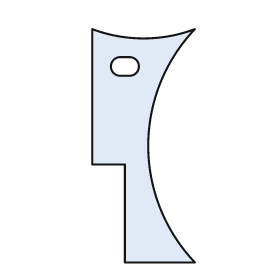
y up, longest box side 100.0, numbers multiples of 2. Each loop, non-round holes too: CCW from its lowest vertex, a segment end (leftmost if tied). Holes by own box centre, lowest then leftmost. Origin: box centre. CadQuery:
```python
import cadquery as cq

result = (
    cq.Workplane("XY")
    .moveTo(-8.0, -50.0)
    .lineTo(22.0, -50.0)
    .threePointArc((2.0, 0.0), (22.0, 50.0))
    .threePointArc((0.0, 46.0), (-22.0, 50.0))
    .lineTo(-22.0, -8.0)
    .lineTo(-8.0, -8.0)
    .close()
    .moveTo(-10.0, 30.0)
    .lineTo(-6.0, 30.0)
    .threePointArc((-2.0, 34.0), (-6.0, 38.0))
    .lineTo(-10.0, 38.0)
    .threePointArc((-14.0, 34.0), (-10.0, 30.0))
    .close()
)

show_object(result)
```